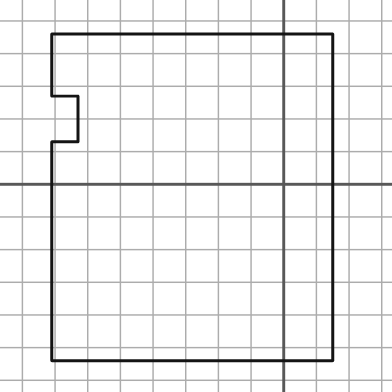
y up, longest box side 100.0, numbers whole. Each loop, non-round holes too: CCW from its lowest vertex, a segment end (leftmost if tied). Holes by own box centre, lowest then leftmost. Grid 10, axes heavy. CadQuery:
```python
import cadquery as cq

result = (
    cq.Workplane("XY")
    .moveTo(-71.0, -54.0)
    .lineTo(15.0, -54.0)
    .lineTo(15.0, 46.0)
    .lineTo(-71.0, 46.0)
    .lineTo(-71.0, 27.0)
    .lineTo(-63.0, 27.0)
    .lineTo(-63.0, 13.0)
    .lineTo(-71.0, 13.0)
    .close()
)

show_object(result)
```